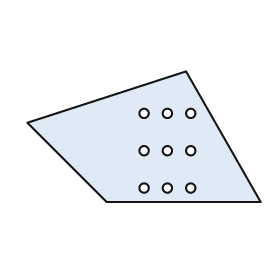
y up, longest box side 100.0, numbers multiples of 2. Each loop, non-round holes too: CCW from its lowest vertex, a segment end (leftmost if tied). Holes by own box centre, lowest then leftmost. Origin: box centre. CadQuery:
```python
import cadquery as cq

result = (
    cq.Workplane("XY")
    .moveTo(-16.0, -28.0)
    .lineTo(50.0, -28.0)
    .lineTo(18.0, 28.0)
    .lineTo(-50.0, 6.0)
    .close()
    .moveTo(0.0, -22.0)
    .circle(2.0)
    .moveTo(10.0, -22.0)
    .circle(2.0)
    .moveTo(20.0, -22.0)
    .circle(2.0)
    .moveTo(0.0, -6.0)
    .circle(2.0)
    .moveTo(10.0, -6.0)
    .circle(2.0)
    .moveTo(20.0, -6.0)
    .circle(2.0)
    .moveTo(0.0, 10.0)
    .circle(2.0)
    .moveTo(10.0, 10.0)
    .circle(2.0)
    .moveTo(20.0, 10.0)
    .circle(2.0)
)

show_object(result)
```